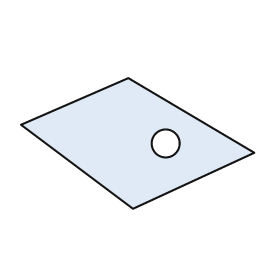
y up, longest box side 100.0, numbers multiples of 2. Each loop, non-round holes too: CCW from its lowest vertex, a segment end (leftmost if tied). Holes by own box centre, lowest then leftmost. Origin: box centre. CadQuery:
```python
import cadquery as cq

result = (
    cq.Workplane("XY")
    .moveTo(-2.0, -28.0)
    .lineTo(50.0, -4.0)
    .lineTo(-4.0, 28.0)
    .lineTo(-50.0, 8.0)
    .close()
    .moveTo(12.0, 0.0)
    .circle(6.0)
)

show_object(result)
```